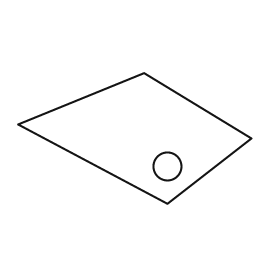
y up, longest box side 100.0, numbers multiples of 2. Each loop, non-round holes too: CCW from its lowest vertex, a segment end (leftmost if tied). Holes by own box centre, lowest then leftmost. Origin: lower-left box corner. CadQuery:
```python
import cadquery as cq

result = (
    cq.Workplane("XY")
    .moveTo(64.0, 0.0)
    .lineTo(100.0, 28.0)
    .lineTo(54.0, 56.0)
    .lineTo(0.0, 34.0)
    .close()
    .moveTo(64.0, 16.0)
    .circle(6.0)
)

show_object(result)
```